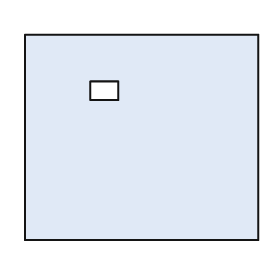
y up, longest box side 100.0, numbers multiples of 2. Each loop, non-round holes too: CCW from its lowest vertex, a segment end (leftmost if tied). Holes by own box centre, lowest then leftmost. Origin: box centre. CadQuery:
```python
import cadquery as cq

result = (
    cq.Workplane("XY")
    .moveTo(-50.0, -44.0)
    .lineTo(50.0, -44.0)
    .lineTo(50.0, 44.0)
    .lineTo(-50.0, 44.0)
    .close()
    .moveTo(-22.0, 16.0)
    .lineTo(-10.0, 16.0)
    .lineTo(-10.0, 24.0)
    .lineTo(-22.0, 24.0)
    .close()
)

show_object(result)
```